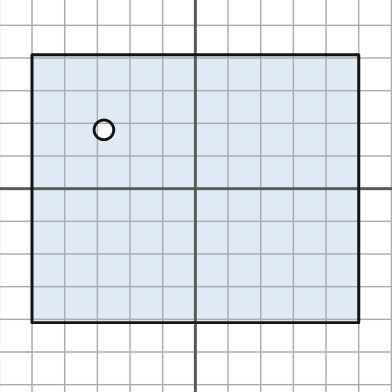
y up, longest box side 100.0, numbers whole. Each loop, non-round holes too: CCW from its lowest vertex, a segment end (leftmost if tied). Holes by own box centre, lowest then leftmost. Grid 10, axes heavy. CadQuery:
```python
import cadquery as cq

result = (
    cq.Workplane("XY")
    .moveTo(-50.0, -41.0)
    .lineTo(50.0, -41.0)
    .lineTo(50.0, 41.0)
    .lineTo(-50.0, 41.0)
    .close()
    .moveTo(-28.0, 18.0)
    .circle(3.0)
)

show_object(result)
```